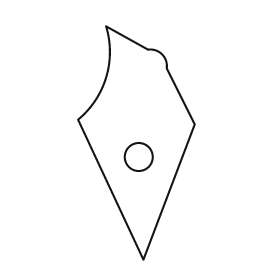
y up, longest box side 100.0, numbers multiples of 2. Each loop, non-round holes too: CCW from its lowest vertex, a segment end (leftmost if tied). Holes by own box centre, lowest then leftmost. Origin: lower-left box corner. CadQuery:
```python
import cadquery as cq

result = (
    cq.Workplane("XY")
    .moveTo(28.0, 0.0)
    .lineTo(50.0, 58.0)
    .lineTo(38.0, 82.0)
    .threePointArc((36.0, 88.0), (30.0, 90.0))
    .lineTo(12.0, 100.0)
    .threePointArc((12.0, 78.0), (0.0, 60.0))
    .close()
    .moveTo(26.0, 44.0)
    .circle(6.0)
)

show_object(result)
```